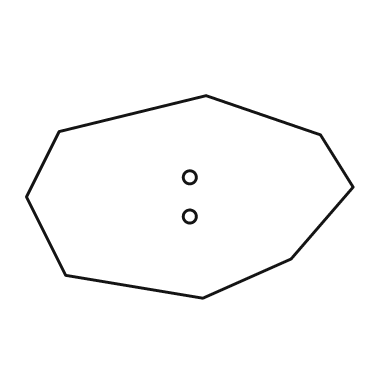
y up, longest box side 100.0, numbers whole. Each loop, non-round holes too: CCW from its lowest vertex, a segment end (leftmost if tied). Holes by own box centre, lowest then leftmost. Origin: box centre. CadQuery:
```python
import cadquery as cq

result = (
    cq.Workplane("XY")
    .moveTo(4.0, -31.0)
    .lineTo(31.0, -19.0)
    .lineTo(50.0, 3.0)
    .lineTo(40.0, 19.0)
    .lineTo(5.0, 31.0)
    .lineTo(-40.0, 20.0)
    .lineTo(-50.0, 0.0)
    .lineTo(-38.0, -24.0)
    .close()
    .moveTo(0.0, -6.0)
    .circle(2.0)
    .moveTo(0.0, 6.0)
    .circle(2.0)
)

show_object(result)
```